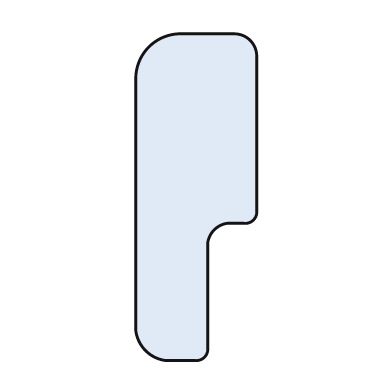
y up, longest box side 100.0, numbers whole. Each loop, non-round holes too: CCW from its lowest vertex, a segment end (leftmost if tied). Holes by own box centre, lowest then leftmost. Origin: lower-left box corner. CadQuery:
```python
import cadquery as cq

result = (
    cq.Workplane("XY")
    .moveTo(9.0, 0.0)
    .lineTo(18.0, 0.0)
    .threePointArc((21.0, 1.0), (22.0, 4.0))
    .lineTo(22.0, 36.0)
    .threePointArc((24.0, 40.0), (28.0, 42.0))
    .lineTo(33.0, 42.0)
    .threePointArc((36.0, 43.0), (37.0, 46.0))
    .lineTo(37.0, 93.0)
    .threePointArc((35.0, 98.0), (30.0, 100.0))
    .lineTo(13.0, 100.0)
    .threePointArc((4.0, 96.0), (0.0, 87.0))
    .lineTo(0.0, 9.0)
    .threePointArc((3.0, 3.0), (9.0, 0.0))
    .close()
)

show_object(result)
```